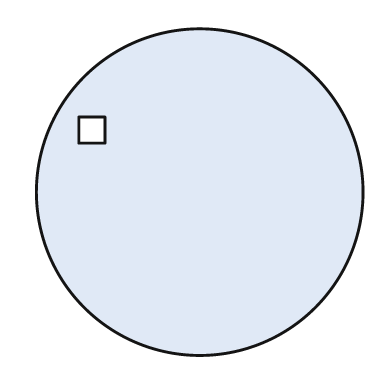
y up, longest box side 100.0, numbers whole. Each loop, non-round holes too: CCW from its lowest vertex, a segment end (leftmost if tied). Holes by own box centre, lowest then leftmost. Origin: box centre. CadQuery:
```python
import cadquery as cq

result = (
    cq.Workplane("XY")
    .moveTo(0.0, 0.0)
    .circle(50.0)
    .moveTo(-37.0, 15.0)
    .lineTo(-29.0, 15.0)
    .lineTo(-29.0, 23.0)
    .lineTo(-37.0, 23.0)
    .close()
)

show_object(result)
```